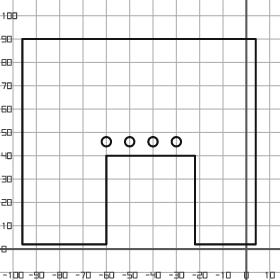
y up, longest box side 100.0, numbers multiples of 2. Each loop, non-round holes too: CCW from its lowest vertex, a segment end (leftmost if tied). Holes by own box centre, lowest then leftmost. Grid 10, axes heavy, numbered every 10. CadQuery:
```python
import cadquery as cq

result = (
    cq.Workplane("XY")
    .moveTo(-96.0, 2.0)
    .lineTo(-60.0, 2.0)
    .lineTo(-60.0, 40.0)
    .lineTo(-22.0, 40.0)
    .lineTo(-22.0, 2.0)
    .lineTo(4.0, 2.0)
    .lineTo(4.0, 90.0)
    .lineTo(-96.0, 90.0)
    .close()
    .moveTo(-60.0, 46.0)
    .circle(2.0)
    .moveTo(-50.0, 46.0)
    .circle(2.0)
    .moveTo(-40.0, 46.0)
    .circle(2.0)
    .moveTo(-30.0, 46.0)
    .circle(2.0)
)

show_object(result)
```